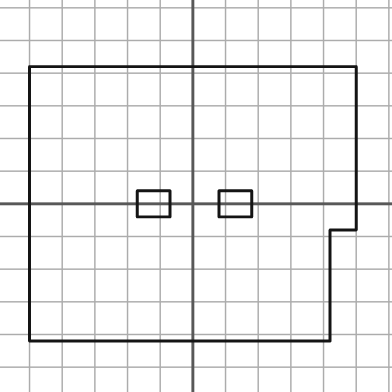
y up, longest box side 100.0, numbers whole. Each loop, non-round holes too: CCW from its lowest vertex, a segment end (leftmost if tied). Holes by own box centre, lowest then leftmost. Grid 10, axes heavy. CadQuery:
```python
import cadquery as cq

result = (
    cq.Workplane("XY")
    .moveTo(-50.0, -42.0)
    .lineTo(42.0, -42.0)
    .lineTo(42.0, -8.0)
    .lineTo(50.0, -8.0)
    .lineTo(50.0, 42.0)
    .lineTo(-50.0, 42.0)
    .close()
    .moveTo(-17.0, -4.0)
    .lineTo(-7.0, -4.0)
    .lineTo(-7.0, 4.0)
    .lineTo(-17.0, 4.0)
    .close()
    .moveTo(8.0, -4.0)
    .lineTo(18.0, -4.0)
    .lineTo(18.0, 4.0)
    .lineTo(8.0, 4.0)
    .close()
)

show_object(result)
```